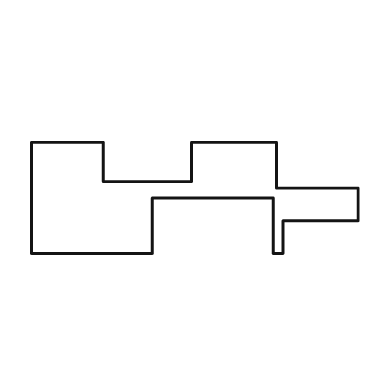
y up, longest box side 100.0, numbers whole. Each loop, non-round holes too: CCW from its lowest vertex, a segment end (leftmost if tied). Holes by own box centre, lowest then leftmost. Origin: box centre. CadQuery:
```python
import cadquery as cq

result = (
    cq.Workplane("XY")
    .moveTo(-50.0, -17.0)
    .lineTo(-13.0, -17.0)
    .lineTo(-13.0, 0.0)
    .lineTo(24.0, 0.0)
    .lineTo(24.0, -17.0)
    .lineTo(27.0, -17.0)
    .lineTo(27.0, -7.0)
    .lineTo(50.0, -7.0)
    .lineTo(50.0, 3.0)
    .lineTo(25.0, 3.0)
    .lineTo(25.0, 17.0)
    .lineTo(-1.0, 17.0)
    .lineTo(-1.0, 5.0)
    .lineTo(-28.0, 5.0)
    .lineTo(-28.0, 17.0)
    .lineTo(-50.0, 17.0)
    .close()
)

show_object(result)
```